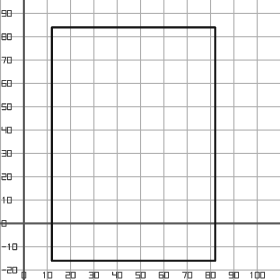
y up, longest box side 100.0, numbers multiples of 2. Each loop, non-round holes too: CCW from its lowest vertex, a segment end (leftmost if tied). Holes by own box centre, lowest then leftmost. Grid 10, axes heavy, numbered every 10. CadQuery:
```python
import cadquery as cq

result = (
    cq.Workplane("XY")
    .moveTo(12.0, -16.0)
    .lineTo(82.0, -16.0)
    .lineTo(82.0, 84.0)
    .lineTo(12.0, 84.0)
    .close()
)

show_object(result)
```